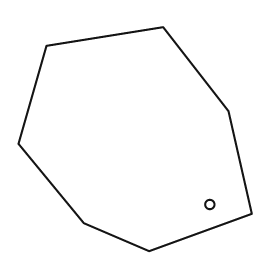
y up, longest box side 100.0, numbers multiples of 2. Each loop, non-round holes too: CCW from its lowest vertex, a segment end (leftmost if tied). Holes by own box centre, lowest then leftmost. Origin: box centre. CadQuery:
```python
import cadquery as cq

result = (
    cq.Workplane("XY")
    .moveTo(6.0, -48.0)
    .lineTo(50.0, -32.0)
    .lineTo(40.0, 12.0)
    .lineTo(12.0, 48.0)
    .lineTo(-38.0, 40.0)
    .lineTo(-50.0, -2.0)
    .lineTo(-22.0, -36.0)
    .close()
    .moveTo(32.0, -28.0)
    .circle(2.0)
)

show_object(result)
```